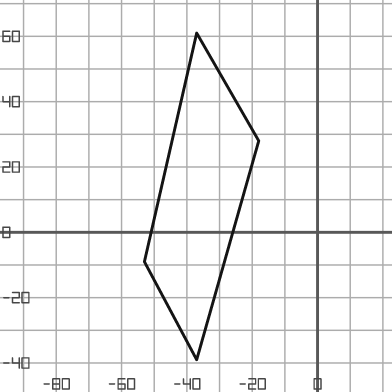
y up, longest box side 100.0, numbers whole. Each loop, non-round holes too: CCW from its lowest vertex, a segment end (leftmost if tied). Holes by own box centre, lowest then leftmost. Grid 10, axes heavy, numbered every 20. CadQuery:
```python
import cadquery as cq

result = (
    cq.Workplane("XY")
    .moveTo(-37.0, -39.0)
    .lineTo(-18.0, 28.0)
    .lineTo(-37.0, 61.0)
    .lineTo(-53.0, -9.0)
    .close()
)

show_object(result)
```